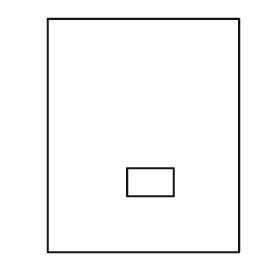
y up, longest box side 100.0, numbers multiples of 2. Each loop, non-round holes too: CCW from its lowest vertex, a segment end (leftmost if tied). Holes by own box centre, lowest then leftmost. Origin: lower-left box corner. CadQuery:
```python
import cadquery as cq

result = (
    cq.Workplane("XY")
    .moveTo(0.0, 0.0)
    .lineTo(82.0, 0.0)
    .lineTo(82.0, 100.0)
    .lineTo(0.0, 100.0)
    .close()
    .moveTo(34.0, 24.0)
    .lineTo(54.0, 24.0)
    .lineTo(54.0, 36.0)
    .lineTo(34.0, 36.0)
    .close()
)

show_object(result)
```